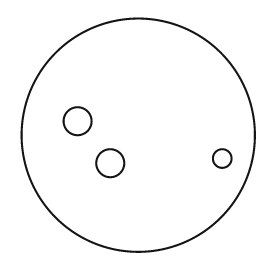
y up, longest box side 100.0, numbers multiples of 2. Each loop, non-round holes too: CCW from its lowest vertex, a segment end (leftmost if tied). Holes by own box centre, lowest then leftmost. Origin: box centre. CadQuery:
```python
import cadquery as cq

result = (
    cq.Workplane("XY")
    .moveTo(0.0, 0.0)
    .circle(50.0)
    .moveTo(-12.0, -12.0)
    .circle(6.0)
    .moveTo(36.0, -10.0)
    .circle(4.0)
    .moveTo(-26.0, 6.0)
    .circle(6.0)
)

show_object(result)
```